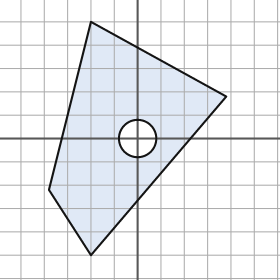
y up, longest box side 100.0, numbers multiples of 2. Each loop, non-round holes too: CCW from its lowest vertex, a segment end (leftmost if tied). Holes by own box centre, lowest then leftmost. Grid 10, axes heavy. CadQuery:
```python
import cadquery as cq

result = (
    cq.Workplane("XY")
    .moveTo(-20.0, -50.0)
    .lineTo(38.0, 18.0)
    .lineTo(-20.0, 50.0)
    .lineTo(-38.0, -22.0)
    .close()
    .moveTo(0.0, 0.0)
    .circle(8.0)
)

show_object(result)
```